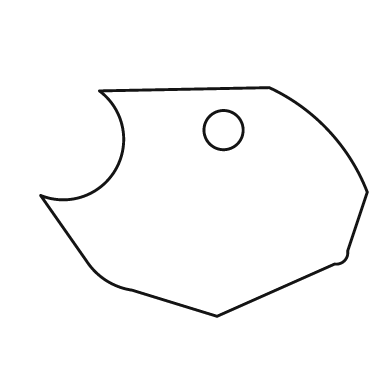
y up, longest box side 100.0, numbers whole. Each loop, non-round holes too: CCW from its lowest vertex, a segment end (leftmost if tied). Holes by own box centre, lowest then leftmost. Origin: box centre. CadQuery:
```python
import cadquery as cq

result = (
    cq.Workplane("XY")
    .moveTo(4.0, -35.0)
    .lineTo(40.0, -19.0)
    .threePointArc((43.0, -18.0), (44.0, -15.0))
    .lineTo(50.0, 3.0)
    .threePointArc((38.0, 22.0), (20.0, 35.0))
    .lineTo(-32.0, 34.0)
    .threePointArc((-27.0, 10.0), (-50.0, 2.0))
    .lineTo(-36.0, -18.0)
    .threePointArc((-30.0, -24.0), (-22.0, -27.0))
    .close()
    .moveTo(6.0, 22.0)
    .circle(6.0)
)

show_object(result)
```